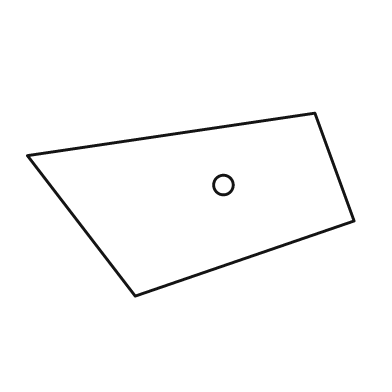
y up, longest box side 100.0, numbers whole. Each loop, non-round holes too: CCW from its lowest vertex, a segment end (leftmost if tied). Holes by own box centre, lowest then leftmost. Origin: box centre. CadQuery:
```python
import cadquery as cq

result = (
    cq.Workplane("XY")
    .moveTo(-17.0, -28.0)
    .lineTo(50.0, -5.0)
    .lineTo(38.0, 28.0)
    .lineTo(-50.0, 15.0)
    .close()
    .moveTo(10.0, 6.0)
    .circle(3.0)
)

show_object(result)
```